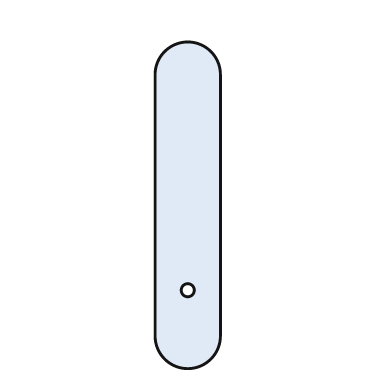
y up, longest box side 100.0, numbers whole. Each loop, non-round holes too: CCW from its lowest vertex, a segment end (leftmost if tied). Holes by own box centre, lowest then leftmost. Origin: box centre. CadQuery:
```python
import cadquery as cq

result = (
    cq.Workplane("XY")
    .moveTo(-10.0, -40.0)
    .threePointArc((0.0, -50.0), (10.0, -40.0))
    .lineTo(10.0, 40.0)
    .threePointArc((0.0, 50.0), (-10.0, 40.0))
    .close()
    .moveTo(0.0, -26.0)
    .circle(2.0)
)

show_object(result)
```